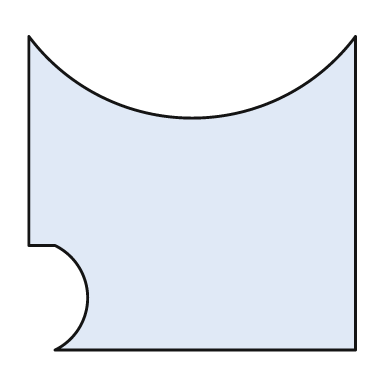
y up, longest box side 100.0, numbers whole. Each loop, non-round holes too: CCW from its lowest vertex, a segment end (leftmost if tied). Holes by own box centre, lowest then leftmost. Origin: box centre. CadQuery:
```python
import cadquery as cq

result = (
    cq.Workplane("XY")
    .moveTo(-42.0, -48.0)
    .lineTo(50.0, -48.0)
    .lineTo(50.0, 48.0)
    .threePointArc((0.0, 23.0), (-50.0, 48.0))
    .lineTo(-50.0, -16.0)
    .lineTo(-42.0, -16.0)
    .threePointArc((-32.0, -32.0), (-42.0, -48.0))
    .close()
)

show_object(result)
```